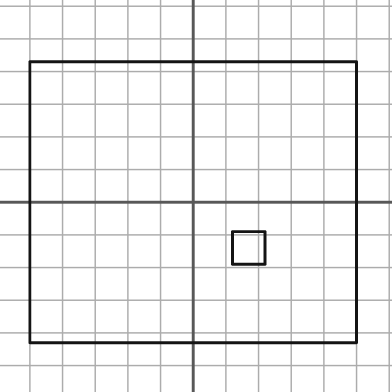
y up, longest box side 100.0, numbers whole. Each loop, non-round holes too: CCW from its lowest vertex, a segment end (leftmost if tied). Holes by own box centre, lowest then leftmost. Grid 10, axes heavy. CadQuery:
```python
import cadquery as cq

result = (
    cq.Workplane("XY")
    .moveTo(-50.0, -43.0)
    .lineTo(50.0, -43.0)
    .lineTo(50.0, 43.0)
    .lineTo(-50.0, 43.0)
    .close()
    .moveTo(12.0, -19.0)
    .lineTo(22.0, -19.0)
    .lineTo(22.0, -9.0)
    .lineTo(12.0, -9.0)
    .close()
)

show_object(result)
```